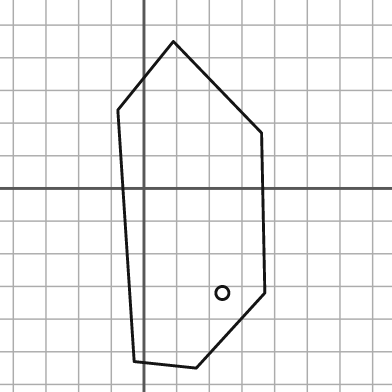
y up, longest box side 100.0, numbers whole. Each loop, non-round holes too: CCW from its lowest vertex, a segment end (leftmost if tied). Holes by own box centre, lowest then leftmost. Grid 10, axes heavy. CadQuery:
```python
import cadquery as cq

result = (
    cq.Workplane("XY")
    .moveTo(16.0, -55.0)
    .lineTo(37.0, -32.0)
    .lineTo(36.0, 17.0)
    .lineTo(9.0, 45.0)
    .lineTo(-8.0, 24.0)
    .lineTo(-3.0, -53.0)
    .close()
    .moveTo(24.0, -32.0)
    .circle(2.0)
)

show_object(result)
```